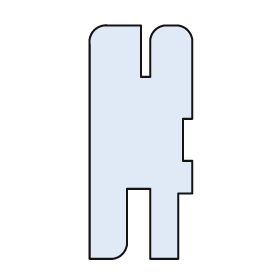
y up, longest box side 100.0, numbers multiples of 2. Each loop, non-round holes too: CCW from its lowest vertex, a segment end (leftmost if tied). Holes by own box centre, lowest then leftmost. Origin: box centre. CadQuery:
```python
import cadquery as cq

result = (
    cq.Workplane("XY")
    .moveTo(-22.0, -50.0)
    .lineTo(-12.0, -50.0)
    .threePointArc((-8.0, -48.0), (-6.0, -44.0))
    .lineTo(-6.0, -20.0)
    .lineTo(4.0, -20.0)
    .lineTo(4.0, -50.0)
    .lineTo(16.0, -50.0)
    .lineTo(16.0, -22.0)
    .lineTo(22.0, -22.0)
    .lineTo(22.0, -8.0)
    .lineTo(18.0, -8.0)
    .lineTo(18.0, 10.0)
    .lineTo(22.0, 10.0)
    .lineTo(22.0, 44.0)
    .threePointArc((20.0, 48.0), (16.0, 50.0))
    .lineTo(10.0, 50.0)
    .threePointArc((6.0, 48.0), (4.0, 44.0))
    .lineTo(4.0, 28.0)
    .lineTo(0.0, 28.0)
    .lineTo(0.0, 50.0)
    .lineTo(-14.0, 50.0)
    .threePointArc((-20.0, 48.0), (-22.0, 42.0))
    .close()
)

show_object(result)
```